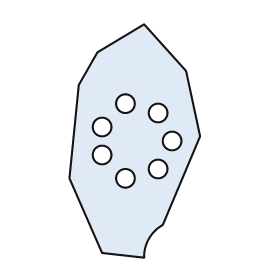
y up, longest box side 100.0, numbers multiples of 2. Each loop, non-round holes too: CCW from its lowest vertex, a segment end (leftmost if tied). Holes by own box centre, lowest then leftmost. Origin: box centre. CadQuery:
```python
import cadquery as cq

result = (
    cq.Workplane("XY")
    .moveTo(4.0, -50.0)
    .threePointArc((6.0, -42.0), (12.0, -36.0))
    .lineTo(28.0, 2.0)
    .lineTo(22.0, 30.0)
    .lineTo(4.0, 50.0)
    .lineTo(-16.0, 38.0)
    .lineTo(-24.0, 24.0)
    .lineTo(-28.0, -16.0)
    .lineTo(-14.0, -48.0)
    .close()
    .moveTo(-4.0, -16.0)
    .circle(4.0)
    .moveTo(10.0, -12.0)
    .circle(4.0)
    .moveTo(-14.0, -6.0)
    .circle(4.0)
    .moveTo(16.0, 0.0)
    .circle(4.0)
    .moveTo(-14.0, 6.0)
    .circle(4.0)
    .moveTo(10.0, 12.0)
    .circle(4.0)
    .moveTo(-4.0, 16.0)
    .circle(4.0)
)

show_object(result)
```